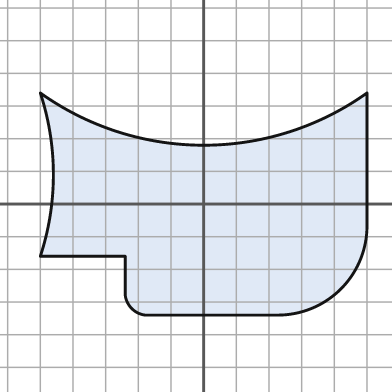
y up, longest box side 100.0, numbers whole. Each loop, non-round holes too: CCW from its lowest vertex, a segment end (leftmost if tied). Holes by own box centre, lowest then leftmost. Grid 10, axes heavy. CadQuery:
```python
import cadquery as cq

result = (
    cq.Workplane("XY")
    .moveTo(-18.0, -34.0)
    .lineTo(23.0, -34.0)
    .threePointArc((42.0, -26.0), (50.0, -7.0))
    .lineTo(50.0, 34.0)
    .threePointArc((0.0, 18.0), (-50.0, 34.0))
    .threePointArc((-46.0, 9.0), (-50.0, -16.0))
    .lineTo(-24.0, -16.0)
    .lineTo(-24.0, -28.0)
    .threePointArc((-22.0, -32.0), (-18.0, -34.0))
    .close()
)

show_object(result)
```